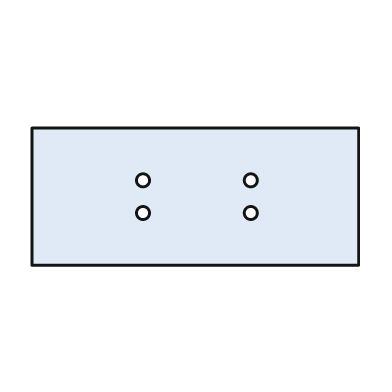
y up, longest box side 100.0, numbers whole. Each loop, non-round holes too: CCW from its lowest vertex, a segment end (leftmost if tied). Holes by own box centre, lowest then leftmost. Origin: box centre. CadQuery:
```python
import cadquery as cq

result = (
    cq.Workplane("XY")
    .moveTo(-50.0, -21.0)
    .lineTo(50.0, -21.0)
    .lineTo(50.0, 21.0)
    .lineTo(-50.0, 21.0)
    .close()
    .moveTo(-16.0, -5.0)
    .circle(2.0)
    .moveTo(17.0, -5.0)
    .circle(2.0)
    .moveTo(-16.0, 5.0)
    .circle(2.0)
    .moveTo(17.0, 5.0)
    .circle(2.0)
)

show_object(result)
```